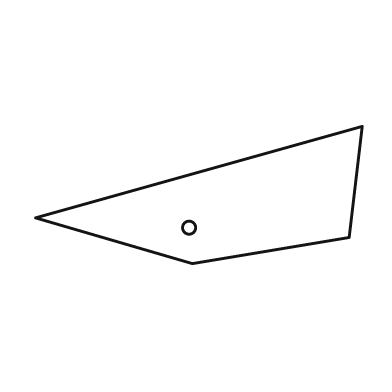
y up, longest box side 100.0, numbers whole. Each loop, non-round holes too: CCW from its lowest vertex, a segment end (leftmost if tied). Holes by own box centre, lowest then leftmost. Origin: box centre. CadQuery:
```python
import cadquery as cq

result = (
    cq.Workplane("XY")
    .moveTo(-2.0, -21.0)
    .lineTo(46.0, -13.0)
    .lineTo(50.0, 21.0)
    .lineTo(-50.0, -7.0)
    .close()
    .moveTo(-3.0, -10.0)
    .circle(2.0)
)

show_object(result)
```